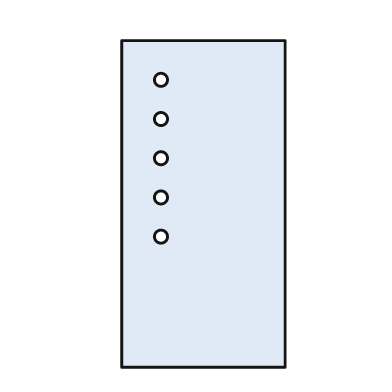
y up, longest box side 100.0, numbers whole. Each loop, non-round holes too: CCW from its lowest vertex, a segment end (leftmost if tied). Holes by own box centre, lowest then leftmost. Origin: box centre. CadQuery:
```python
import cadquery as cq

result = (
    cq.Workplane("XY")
    .moveTo(-25.0, -50.0)
    .lineTo(25.0, -50.0)
    .lineTo(25.0, 50.0)
    .lineTo(-25.0, 50.0)
    .close()
    .moveTo(-13.0, -10.0)
    .circle(2.0)
    .moveTo(-13.0, 2.0)
    .circle(2.0)
    .moveTo(-13.0, 14.0)
    .circle(2.0)
    .moveTo(-13.0, 26.0)
    .circle(2.0)
    .moveTo(-13.0, 38.0)
    .circle(2.0)
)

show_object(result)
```